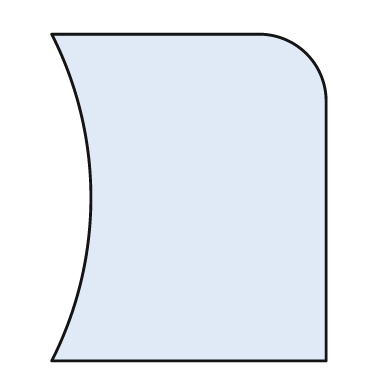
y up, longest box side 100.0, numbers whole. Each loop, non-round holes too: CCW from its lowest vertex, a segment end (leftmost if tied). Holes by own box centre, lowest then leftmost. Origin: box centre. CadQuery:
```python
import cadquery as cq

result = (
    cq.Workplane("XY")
    .moveTo(-42.0, -50.0)
    .lineTo(42.0, -50.0)
    .lineTo(42.0, 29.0)
    .threePointArc((36.0, 44.0), (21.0, 50.0))
    .lineTo(-42.0, 50.0)
    .threePointArc((-30.0, 0.0), (-42.0, -50.0))
    .close()
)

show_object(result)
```